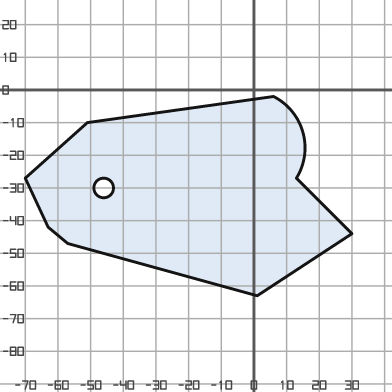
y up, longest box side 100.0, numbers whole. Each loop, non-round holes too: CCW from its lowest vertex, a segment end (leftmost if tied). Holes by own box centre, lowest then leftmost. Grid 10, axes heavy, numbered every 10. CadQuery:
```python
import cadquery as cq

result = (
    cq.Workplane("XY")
    .moveTo(1.0, -63.0)
    .lineTo(30.0, -44.0)
    .lineTo(13.0, -27.0)
    .threePointArc((15.0, -13.0), (6.0, -2.0))
    .lineTo(-51.0, -10.0)
    .lineTo(-70.0, -27.0)
    .lineTo(-63.0, -42.0)
    .lineTo(-57.0, -47.0)
    .close()
    .moveTo(-46.0, -30.0)
    .circle(3.0)
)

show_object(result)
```